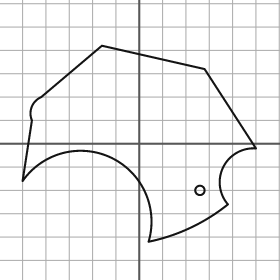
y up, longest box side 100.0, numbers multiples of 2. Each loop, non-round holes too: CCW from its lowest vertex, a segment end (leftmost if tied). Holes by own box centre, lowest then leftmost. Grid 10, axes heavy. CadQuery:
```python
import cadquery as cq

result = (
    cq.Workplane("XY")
    .moveTo(4.0, -42.0)
    .threePointArc((22.0, -36.0), (38.0, -26.0))
    .threePointArc((36.0, -10.0), (50.0, -2.0))
    .lineTo(28.0, 32.0)
    .lineTo(-16.0, 42.0)
    .lineTo(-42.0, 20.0)
    .threePointArc((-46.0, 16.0), (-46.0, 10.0))
    .lineTo(-50.0, -16.0)
    .threePointArc((-12.0, -6.0), (4.0, -42.0))
    .close()
    .moveTo(26.0, -20.0)
    .circle(2.0)
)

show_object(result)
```